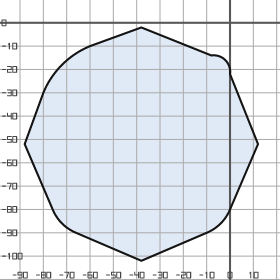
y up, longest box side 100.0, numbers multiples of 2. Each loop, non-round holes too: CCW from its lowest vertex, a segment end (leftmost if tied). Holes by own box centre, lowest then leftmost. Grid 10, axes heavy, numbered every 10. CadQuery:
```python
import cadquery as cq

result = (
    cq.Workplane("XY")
    .moveTo(-38.0, -102.0)
    .lineTo(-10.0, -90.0)
    .threePointArc((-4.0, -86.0), (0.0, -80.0))
    .lineTo(12.0, -52.0)
    .lineTo(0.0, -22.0)
    .threePointArc((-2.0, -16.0), (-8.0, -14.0))
    .lineTo(-38.0, -2.0)
    .lineTo(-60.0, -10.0)
    .threePointArc((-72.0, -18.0), (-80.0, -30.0))
    .lineTo(-88.0, -52.0)
    .lineTo(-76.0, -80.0)
    .threePointArc((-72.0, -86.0), (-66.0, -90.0))
    .close()
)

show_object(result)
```